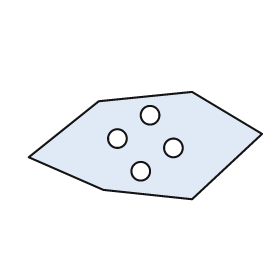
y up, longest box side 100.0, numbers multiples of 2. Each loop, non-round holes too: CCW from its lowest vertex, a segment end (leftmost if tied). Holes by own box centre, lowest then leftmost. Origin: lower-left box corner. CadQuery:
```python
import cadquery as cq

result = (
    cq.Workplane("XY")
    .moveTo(70.0, 0.0)
    .lineTo(100.0, 28.0)
    .lineTo(70.0, 46.0)
    .lineTo(30.0, 42.0)
    .lineTo(0.0, 18.0)
    .lineTo(32.0, 4.0)
    .close()
    .moveTo(48.0, 12.0)
    .circle(4.0)
    .moveTo(62.0, 22.0)
    .circle(4.0)
    .moveTo(38.0, 26.0)
    .circle(4.0)
    .moveTo(52.0, 36.0)
    .circle(4.0)
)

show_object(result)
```